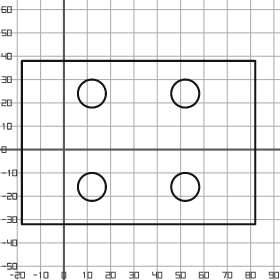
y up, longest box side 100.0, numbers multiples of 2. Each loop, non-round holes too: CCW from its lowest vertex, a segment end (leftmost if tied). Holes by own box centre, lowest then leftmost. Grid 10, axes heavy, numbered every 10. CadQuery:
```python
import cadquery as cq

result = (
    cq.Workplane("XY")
    .moveTo(-18.0, -32.0)
    .lineTo(82.0, -32.0)
    .lineTo(82.0, 38.0)
    .lineTo(-18.0, 38.0)
    .close()
    .moveTo(12.0, -16.0)
    .circle(6.0)
    .moveTo(52.0, -16.0)
    .circle(6.0)
    .moveTo(12.0, 24.0)
    .circle(6.0)
    .moveTo(52.0, 24.0)
    .circle(6.0)
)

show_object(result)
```